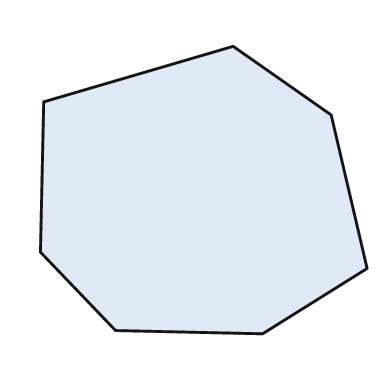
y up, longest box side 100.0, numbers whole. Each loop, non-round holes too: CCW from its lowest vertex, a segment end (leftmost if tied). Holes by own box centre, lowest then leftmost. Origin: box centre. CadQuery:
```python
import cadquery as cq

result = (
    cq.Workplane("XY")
    .moveTo(18.0, -44.0)
    .lineTo(50.0, -24.0)
    .lineTo(39.0, 23.0)
    .lineTo(9.0, 44.0)
    .lineTo(-49.0, 27.0)
    .lineTo(-50.0, -19.0)
    .lineTo(-27.0, -43.0)
    .close()
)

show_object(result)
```